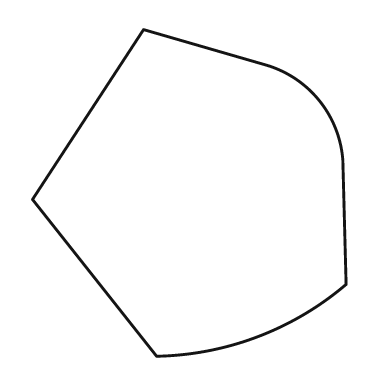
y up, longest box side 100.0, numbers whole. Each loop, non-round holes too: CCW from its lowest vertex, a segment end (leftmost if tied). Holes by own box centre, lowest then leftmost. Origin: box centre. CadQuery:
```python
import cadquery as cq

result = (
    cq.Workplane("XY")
    .moveTo(-10.0, -50.0)
    .threePointArc((21.0, -44.0), (48.0, -28.0))
    .lineTo(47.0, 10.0)
    .threePointArc((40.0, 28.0), (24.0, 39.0))
    .lineTo(-14.0, 50.0)
    .lineTo(-48.0, -2.0)
    .close()
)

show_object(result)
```